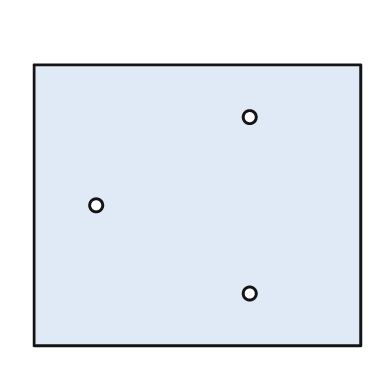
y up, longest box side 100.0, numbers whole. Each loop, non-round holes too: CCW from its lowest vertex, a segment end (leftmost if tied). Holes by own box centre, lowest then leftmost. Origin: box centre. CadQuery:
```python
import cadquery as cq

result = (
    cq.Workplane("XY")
    .moveTo(-50.0, -43.0)
    .lineTo(50.0, -43.0)
    .lineTo(50.0, 43.0)
    .lineTo(-50.0, 43.0)
    .close()
    .moveTo(16.0, -27.0)
    .circle(2.0)
    .moveTo(-31.0, 0.0)
    .circle(2.0)
    .moveTo(16.0, 27.0)
    .circle(2.0)
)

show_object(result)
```